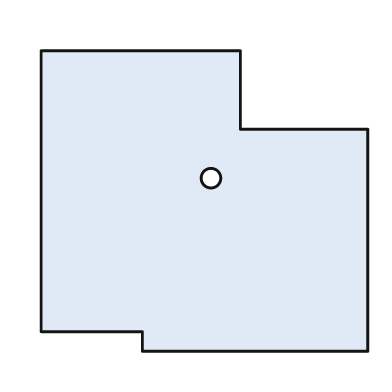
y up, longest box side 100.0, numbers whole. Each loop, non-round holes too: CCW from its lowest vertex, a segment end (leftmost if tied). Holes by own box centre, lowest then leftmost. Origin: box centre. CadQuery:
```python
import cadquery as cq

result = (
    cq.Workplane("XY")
    .moveTo(-19.0, -46.0)
    .lineTo(50.0, -46.0)
    .lineTo(50.0, 22.0)
    .lineTo(11.0, 22.0)
    .lineTo(11.0, 46.0)
    .lineTo(-50.0, 46.0)
    .lineTo(-50.0, -40.0)
    .lineTo(-19.0, -40.0)
    .close()
    .moveTo(2.0, 7.0)
    .circle(3.0)
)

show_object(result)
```